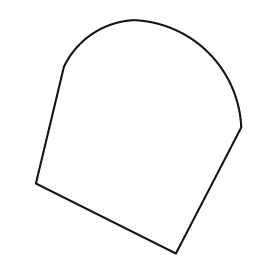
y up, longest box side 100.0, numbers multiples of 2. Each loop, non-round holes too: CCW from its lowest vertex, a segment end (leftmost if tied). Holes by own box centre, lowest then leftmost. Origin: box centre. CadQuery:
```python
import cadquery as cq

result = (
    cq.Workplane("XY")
    .moveTo(16.0, -50.0)
    .lineTo(44.0, 4.0)
    .threePointArc((30.0, 36.0), (-2.0, 50.0))
    .threePointArc((-20.0, 44.0), (-32.0, 30.0))
    .lineTo(-44.0, -20.0)
    .close()
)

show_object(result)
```